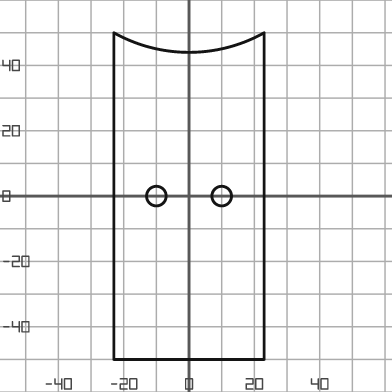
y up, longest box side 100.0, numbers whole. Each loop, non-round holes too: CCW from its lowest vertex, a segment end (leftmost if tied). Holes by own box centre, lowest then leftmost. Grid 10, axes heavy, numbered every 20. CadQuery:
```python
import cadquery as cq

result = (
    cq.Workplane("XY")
    .moveTo(-23.0, -50.0)
    .lineTo(23.0, -50.0)
    .lineTo(23.0, 50.0)
    .threePointArc((0.0, 44.0), (-23.0, 50.0))
    .close()
    .moveTo(-10.0, 0.0)
    .circle(3.0)
    .moveTo(10.0, 0.0)
    .circle(3.0)
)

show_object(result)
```